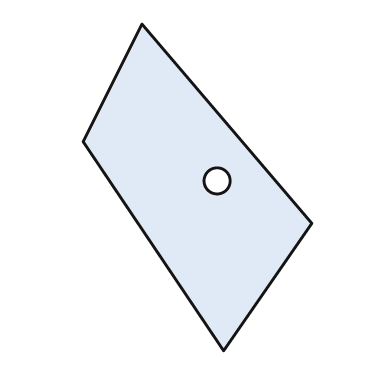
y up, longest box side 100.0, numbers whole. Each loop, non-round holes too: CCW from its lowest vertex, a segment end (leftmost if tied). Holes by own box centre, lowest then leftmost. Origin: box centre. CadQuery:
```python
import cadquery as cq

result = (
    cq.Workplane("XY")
    .moveTo(8.0, -50.0)
    .lineTo(35.0, -11.0)
    .lineTo(-17.0, 50.0)
    .lineTo(-35.0, 14.0)
    .close()
    .moveTo(6.0, 2.0)
    .circle(4.0)
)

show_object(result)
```